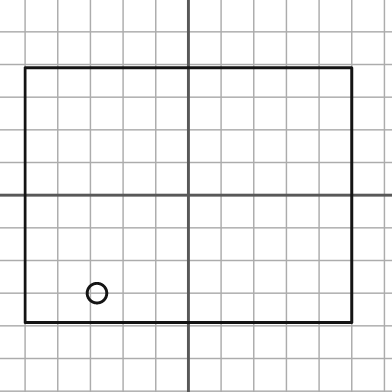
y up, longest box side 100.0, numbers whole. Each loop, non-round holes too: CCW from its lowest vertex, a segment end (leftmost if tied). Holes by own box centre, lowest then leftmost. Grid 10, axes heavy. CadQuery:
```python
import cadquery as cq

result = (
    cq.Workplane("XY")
    .moveTo(-50.0, -39.0)
    .lineTo(50.0, -39.0)
    .lineTo(50.0, 39.0)
    .lineTo(-50.0, 39.0)
    .close()
    .moveTo(-28.0, -30.0)
    .circle(3.0)
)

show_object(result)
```